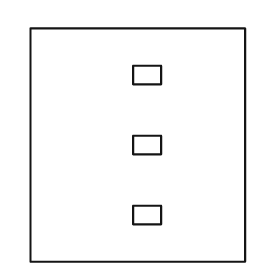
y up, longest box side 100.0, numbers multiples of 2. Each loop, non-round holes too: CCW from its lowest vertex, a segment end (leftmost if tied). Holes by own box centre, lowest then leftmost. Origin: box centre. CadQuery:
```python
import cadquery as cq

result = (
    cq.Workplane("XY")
    .moveTo(-46.0, -50.0)
    .lineTo(46.0, -50.0)
    .lineTo(46.0, 50.0)
    .lineTo(-46.0, 50.0)
    .close()
    .moveTo(-2.0, -34.0)
    .lineTo(10.0, -34.0)
    .lineTo(10.0, -26.0)
    .lineTo(-2.0, -26.0)
    .close()
    .moveTo(-2.0, -4.0)
    .lineTo(10.0, -4.0)
    .lineTo(10.0, 4.0)
    .lineTo(-2.0, 4.0)
    .close()
    .moveTo(-2.0, 26.0)
    .lineTo(10.0, 26.0)
    .lineTo(10.0, 34.0)
    .lineTo(-2.0, 34.0)
    .close()
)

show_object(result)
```